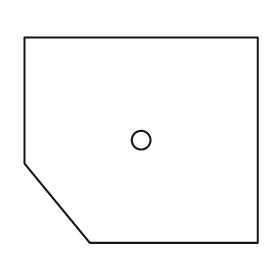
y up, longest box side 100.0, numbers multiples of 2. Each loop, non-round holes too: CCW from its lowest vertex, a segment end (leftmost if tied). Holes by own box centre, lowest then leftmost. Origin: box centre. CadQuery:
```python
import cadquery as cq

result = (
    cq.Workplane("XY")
    .moveTo(-22.0, -44.0)
    .lineTo(50.0, -44.0)
    .lineTo(50.0, 44.0)
    .lineTo(-50.0, 44.0)
    .lineTo(-50.0, -10.0)
    .close()
    .moveTo(0.0, 0.0)
    .circle(4.0)
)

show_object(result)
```